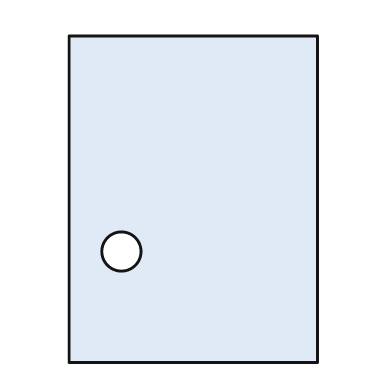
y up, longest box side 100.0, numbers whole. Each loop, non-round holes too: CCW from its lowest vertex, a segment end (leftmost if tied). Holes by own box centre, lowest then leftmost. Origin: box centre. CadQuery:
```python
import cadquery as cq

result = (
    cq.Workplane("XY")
    .moveTo(-38.0, -50.0)
    .lineTo(38.0, -50.0)
    .lineTo(38.0, 50.0)
    .lineTo(-38.0, 50.0)
    .close()
    .moveTo(-22.0, -16.0)
    .circle(6.0)
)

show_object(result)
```